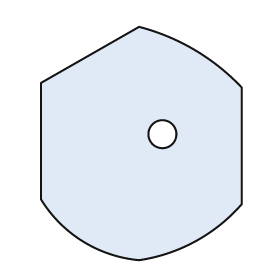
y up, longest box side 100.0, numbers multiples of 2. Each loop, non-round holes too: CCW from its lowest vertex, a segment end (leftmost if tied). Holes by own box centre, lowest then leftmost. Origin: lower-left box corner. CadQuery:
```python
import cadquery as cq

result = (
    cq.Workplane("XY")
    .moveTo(42.0, 0.0)
    .threePointArc((66.0, 8.0), (86.0, 24.0))
    .lineTo(86.0, 74.0)
    .threePointArc((66.0, 90.0), (42.0, 100.0))
    .lineTo(0.0, 76.0)
    .lineTo(0.0, 26.0)
    .threePointArc((18.0, 8.0), (42.0, 0.0))
    .close()
    .moveTo(52.0, 54.0)
    .circle(6.0)
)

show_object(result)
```